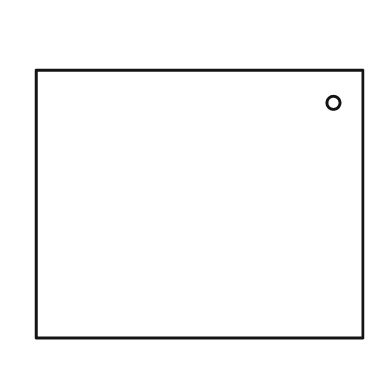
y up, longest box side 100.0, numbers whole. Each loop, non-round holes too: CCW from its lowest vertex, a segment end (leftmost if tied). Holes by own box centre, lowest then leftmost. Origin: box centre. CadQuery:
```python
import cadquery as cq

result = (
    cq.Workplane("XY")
    .moveTo(-50.0, -41.0)
    .lineTo(50.0, -41.0)
    .lineTo(50.0, 41.0)
    .lineTo(-50.0, 41.0)
    .close()
    .moveTo(41.0, 31.0)
    .circle(2.0)
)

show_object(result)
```